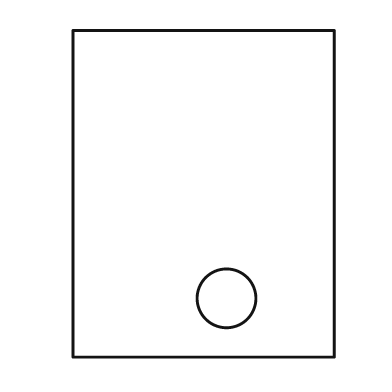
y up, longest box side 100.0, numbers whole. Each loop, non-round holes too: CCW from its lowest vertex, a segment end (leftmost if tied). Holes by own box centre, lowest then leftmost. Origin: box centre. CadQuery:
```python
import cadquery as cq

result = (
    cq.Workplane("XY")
    .moveTo(-40.0, -50.0)
    .lineTo(40.0, -50.0)
    .lineTo(40.0, 50.0)
    .lineTo(-40.0, 50.0)
    .close()
    .moveTo(7.0, -32.0)
    .circle(9.0)
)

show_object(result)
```